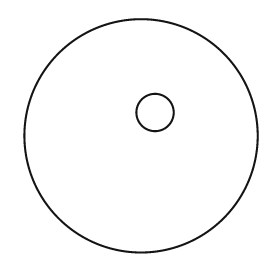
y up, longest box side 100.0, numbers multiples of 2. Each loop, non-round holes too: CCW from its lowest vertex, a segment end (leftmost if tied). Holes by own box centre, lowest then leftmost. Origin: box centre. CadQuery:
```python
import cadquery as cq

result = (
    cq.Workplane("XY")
    .moveTo(0.0, 0.0)
    .circle(50.0)
    .moveTo(6.0, 10.0)
    .circle(8.0)
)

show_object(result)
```